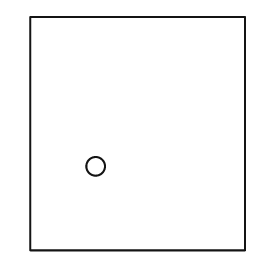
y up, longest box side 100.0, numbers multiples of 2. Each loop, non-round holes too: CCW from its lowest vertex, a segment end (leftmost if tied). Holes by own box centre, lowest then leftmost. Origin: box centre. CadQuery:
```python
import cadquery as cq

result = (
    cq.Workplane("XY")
    .moveTo(-46.0, -50.0)
    .lineTo(46.0, -50.0)
    .lineTo(46.0, 50.0)
    .lineTo(-46.0, 50.0)
    .close()
    .moveTo(-18.0, -14.0)
    .circle(4.0)
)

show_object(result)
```